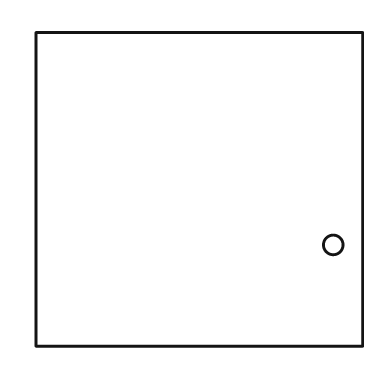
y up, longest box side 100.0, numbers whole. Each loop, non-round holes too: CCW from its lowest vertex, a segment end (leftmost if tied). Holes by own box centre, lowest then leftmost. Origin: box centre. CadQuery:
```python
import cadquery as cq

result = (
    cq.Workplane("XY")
    .moveTo(-50.0, -48.0)
    .lineTo(50.0, -48.0)
    .lineTo(50.0, 48.0)
    .lineTo(-50.0, 48.0)
    .close()
    .moveTo(41.0, -17.0)
    .circle(3.0)
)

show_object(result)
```